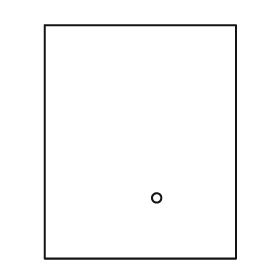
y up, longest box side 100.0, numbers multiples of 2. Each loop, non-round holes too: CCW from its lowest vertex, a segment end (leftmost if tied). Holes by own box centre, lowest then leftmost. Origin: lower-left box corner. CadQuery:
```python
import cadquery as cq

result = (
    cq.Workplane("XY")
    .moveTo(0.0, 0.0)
    .lineTo(82.0, 0.0)
    .lineTo(82.0, 100.0)
    .lineTo(0.0, 100.0)
    .close()
    .moveTo(48.0, 26.0)
    .circle(2.0)
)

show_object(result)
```